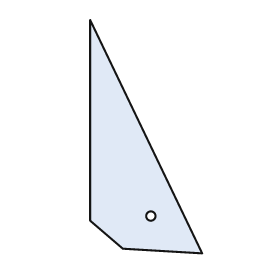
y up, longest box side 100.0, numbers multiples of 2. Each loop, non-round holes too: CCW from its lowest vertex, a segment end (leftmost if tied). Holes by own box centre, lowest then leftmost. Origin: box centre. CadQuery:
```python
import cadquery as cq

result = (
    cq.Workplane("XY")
    .moveTo(24.0, -50.0)
    .lineTo(-24.0, 50.0)
    .lineTo(-24.0, -36.0)
    .lineTo(-10.0, -48.0)
    .close()
    .moveTo(2.0, -34.0)
    .circle(2.0)
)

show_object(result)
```